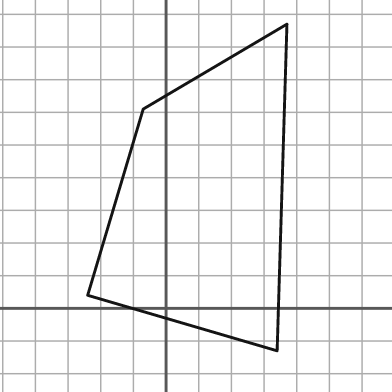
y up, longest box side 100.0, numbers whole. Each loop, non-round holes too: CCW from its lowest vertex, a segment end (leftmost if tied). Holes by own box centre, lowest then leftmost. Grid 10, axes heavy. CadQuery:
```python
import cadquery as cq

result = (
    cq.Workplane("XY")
    .moveTo(34.0, -13.0)
    .lineTo(37.0, 87.0)
    .lineTo(-7.0, 61.0)
    .lineTo(-24.0, 4.0)
    .close()
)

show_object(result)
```